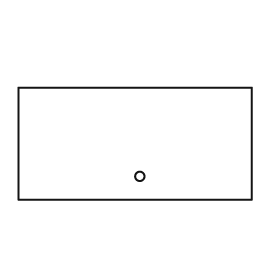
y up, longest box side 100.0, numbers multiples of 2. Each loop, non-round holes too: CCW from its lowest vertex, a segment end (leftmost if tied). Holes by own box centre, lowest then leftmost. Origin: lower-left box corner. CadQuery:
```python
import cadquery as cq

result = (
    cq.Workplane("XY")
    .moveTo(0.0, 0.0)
    .lineTo(100.0, 0.0)
    .lineTo(100.0, 48.0)
    .lineTo(0.0, 48.0)
    .close()
    .moveTo(52.0, 10.0)
    .circle(2.0)
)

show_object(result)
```